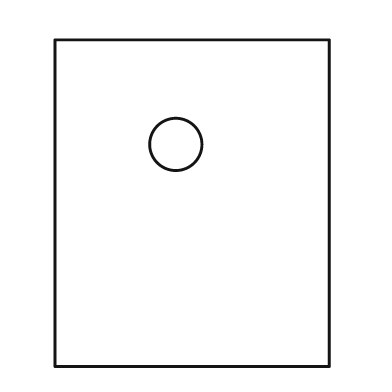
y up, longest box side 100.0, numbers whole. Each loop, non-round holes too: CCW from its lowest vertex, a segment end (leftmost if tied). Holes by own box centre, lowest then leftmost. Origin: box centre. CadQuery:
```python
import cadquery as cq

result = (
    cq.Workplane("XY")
    .moveTo(-42.0, -50.0)
    .lineTo(42.0, -50.0)
    .lineTo(42.0, 50.0)
    .lineTo(-42.0, 50.0)
    .close()
    .moveTo(-5.0, 18.0)
    .circle(8.0)
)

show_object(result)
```